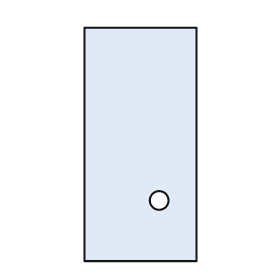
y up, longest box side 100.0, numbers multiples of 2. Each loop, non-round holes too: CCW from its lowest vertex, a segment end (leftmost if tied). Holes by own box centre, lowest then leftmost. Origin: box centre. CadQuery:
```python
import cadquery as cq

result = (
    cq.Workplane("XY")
    .moveTo(-24.0, -50.0)
    .lineTo(24.0, -50.0)
    .lineTo(24.0, 50.0)
    .lineTo(-24.0, 50.0)
    .close()
    .moveTo(8.0, -24.0)
    .circle(4.0)
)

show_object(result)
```